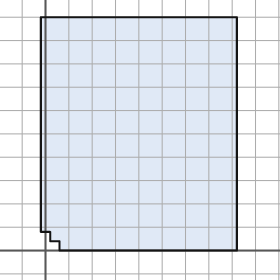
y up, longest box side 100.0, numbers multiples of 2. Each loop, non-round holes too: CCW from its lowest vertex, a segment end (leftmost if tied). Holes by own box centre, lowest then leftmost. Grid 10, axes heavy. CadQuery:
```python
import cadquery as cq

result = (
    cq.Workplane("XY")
    .moveTo(6.0, 0.0)
    .lineTo(82.0, 0.0)
    .lineTo(82.0, 100.0)
    .lineTo(-2.0, 100.0)
    .lineTo(-2.0, 8.0)
    .lineTo(2.0, 8.0)
    .lineTo(2.0, 4.0)
    .lineTo(6.0, 4.0)
    .close()
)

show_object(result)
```